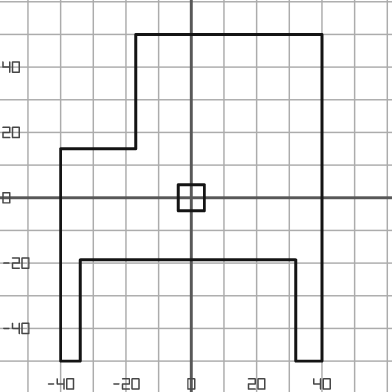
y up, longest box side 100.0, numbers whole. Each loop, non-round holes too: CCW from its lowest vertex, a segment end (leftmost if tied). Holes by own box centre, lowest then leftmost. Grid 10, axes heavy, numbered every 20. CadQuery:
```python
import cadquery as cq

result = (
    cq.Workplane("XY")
    .moveTo(-40.0, -50.0)
    .lineTo(-34.0, -50.0)
    .lineTo(-34.0, -19.0)
    .lineTo(32.0, -19.0)
    .lineTo(32.0, -50.0)
    .lineTo(40.0, -50.0)
    .lineTo(40.0, 50.0)
    .lineTo(-17.0, 50.0)
    .lineTo(-17.0, 15.0)
    .lineTo(-40.0, 15.0)
    .close()
    .moveTo(-4.0, -4.0)
    .lineTo(4.0, -4.0)
    .lineTo(4.0, 4.0)
    .lineTo(-4.0, 4.0)
    .close()
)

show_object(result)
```